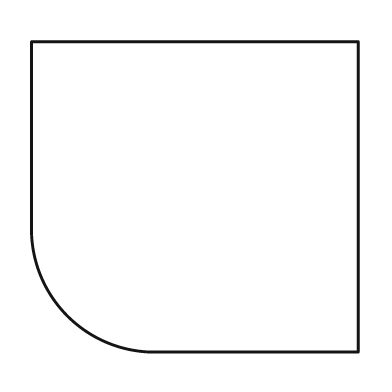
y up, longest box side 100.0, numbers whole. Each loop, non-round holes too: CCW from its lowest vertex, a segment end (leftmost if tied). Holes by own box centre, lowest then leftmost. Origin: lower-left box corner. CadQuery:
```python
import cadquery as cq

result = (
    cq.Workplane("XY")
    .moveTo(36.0, 0.0)
    .lineTo(100.0, 0.0)
    .lineTo(100.0, 95.0)
    .lineTo(0.0, 95.0)
    .lineTo(0.0, 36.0)
    .threePointArc((11.0, 11.0), (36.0, 0.0))
    .close()
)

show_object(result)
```